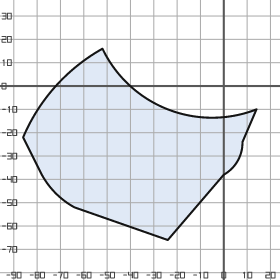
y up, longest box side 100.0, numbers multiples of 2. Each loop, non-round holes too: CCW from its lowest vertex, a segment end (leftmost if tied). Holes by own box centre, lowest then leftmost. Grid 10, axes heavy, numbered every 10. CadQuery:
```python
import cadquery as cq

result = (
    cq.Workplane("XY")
    .moveTo(-24.0, -66.0)
    .lineTo(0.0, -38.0)
    .threePointArc((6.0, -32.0), (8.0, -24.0))
    .lineTo(14.0, -10.0)
    .threePointArc((-24.0, -10.0), (-52.0, 16.0))
    .threePointArc((-72.0, 0.0), (-86.0, -22.0))
    .lineTo(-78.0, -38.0)
    .threePointArc((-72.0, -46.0), (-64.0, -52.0))
    .close()
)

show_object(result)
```